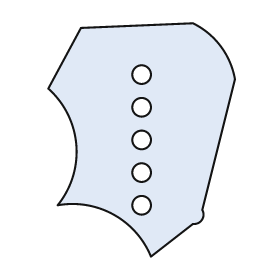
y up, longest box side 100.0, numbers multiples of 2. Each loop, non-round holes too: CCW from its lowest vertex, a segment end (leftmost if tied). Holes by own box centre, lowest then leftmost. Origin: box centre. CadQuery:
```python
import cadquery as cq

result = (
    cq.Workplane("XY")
    .moveTo(4.0, -50.0)
    .lineTo(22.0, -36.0)
    .threePointArc((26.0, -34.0), (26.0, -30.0))
    .lineTo(40.0, 26.0)
    .threePointArc((34.0, 40.0), (22.0, 50.0))
    .lineTo(-26.0, 48.0)
    .lineTo(-40.0, 22.0)
    .threePointArc((-28.0, -2.0), (-36.0, -28.0))
    .threePointArc((-12.0, -32.0), (4.0, -50.0))
    .close()
    .moveTo(0.0, -28.0)
    .circle(4.0)
    .moveTo(0.0, -14.0)
    .circle(4.0)
    .moveTo(0.0, 0.0)
    .circle(4.0)
    .moveTo(0.0, 14.0)
    .circle(4.0)
    .moveTo(0.0, 28.0)
    .circle(4.0)
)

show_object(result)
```